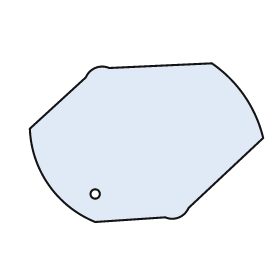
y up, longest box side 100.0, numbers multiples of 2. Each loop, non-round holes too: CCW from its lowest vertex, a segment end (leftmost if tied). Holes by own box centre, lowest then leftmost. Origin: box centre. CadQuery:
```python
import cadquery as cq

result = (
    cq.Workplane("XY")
    .moveTo(-22.0, -34.0)
    .lineTo(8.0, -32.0)
    .threePointArc((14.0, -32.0), (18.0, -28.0))
    .lineTo(50.0, 2.0)
    .threePointArc((42.0, 20.0), (28.0, 34.0))
    .lineTo(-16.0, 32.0)
    .threePointArc((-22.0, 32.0), (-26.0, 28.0))
    .lineTo(-50.0, 6.0)
    .threePointArc((-42.0, -18.0), (-22.0, -34.0))
    .close()
    .moveTo(-22.0, -22.0)
    .circle(2.0)
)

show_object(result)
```